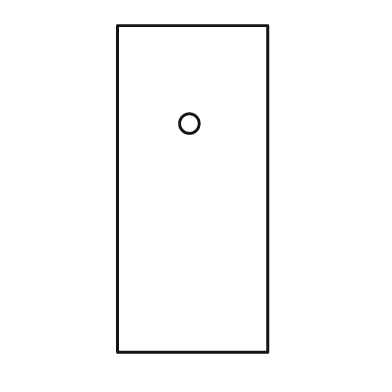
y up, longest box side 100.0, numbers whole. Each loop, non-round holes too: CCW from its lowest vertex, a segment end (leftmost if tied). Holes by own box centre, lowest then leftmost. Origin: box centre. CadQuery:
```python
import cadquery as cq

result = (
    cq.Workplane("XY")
    .moveTo(-23.0, -50.0)
    .lineTo(23.0, -50.0)
    .lineTo(23.0, 50.0)
    .lineTo(-23.0, 50.0)
    .close()
    .moveTo(-1.0, 20.0)
    .circle(3.0)
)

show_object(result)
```